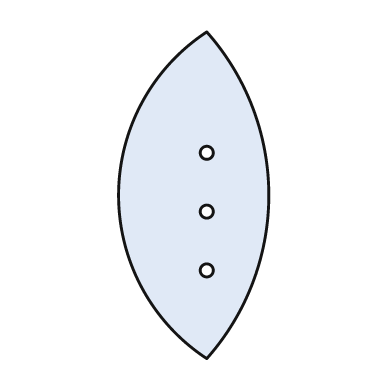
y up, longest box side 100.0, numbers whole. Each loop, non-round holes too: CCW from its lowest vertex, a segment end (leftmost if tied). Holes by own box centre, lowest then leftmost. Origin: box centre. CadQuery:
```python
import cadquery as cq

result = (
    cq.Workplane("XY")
    .moveTo(4.0, -50.0)
    .threePointArc((23.0, 0.0), (4.0, 50.0))
    .threePointArc((-23.0, 0.0), (4.0, -50.0))
    .close()
    .moveTo(4.0, -23.0)
    .circle(2.0)
    .moveTo(4.0, -5.0)
    .circle(2.0)
    .moveTo(4.0, 13.0)
    .circle(2.0)
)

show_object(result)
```